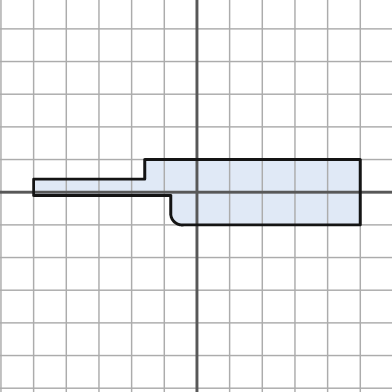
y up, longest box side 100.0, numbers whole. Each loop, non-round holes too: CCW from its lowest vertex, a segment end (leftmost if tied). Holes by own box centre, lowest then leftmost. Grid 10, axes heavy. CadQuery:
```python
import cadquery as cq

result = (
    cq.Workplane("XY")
    .moveTo(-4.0, -10.0)
    .lineTo(50.0, -10.0)
    .lineTo(50.0, 10.0)
    .lineTo(-16.0, 10.0)
    .lineTo(-16.0, 4.0)
    .lineTo(-50.0, 4.0)
    .lineTo(-50.0, -1.0)
    .lineTo(-8.0, -1.0)
    .lineTo(-8.0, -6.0)
    .threePointArc((-7.0, -9.0), (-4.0, -10.0))
    .close()
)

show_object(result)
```